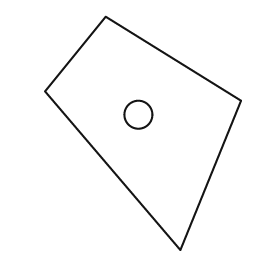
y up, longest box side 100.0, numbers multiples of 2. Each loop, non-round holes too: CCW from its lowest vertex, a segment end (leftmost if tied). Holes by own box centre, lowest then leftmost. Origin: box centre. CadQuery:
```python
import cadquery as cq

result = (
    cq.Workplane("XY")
    .moveTo(16.0, -50.0)
    .lineTo(42.0, 14.0)
    .lineTo(-16.0, 50.0)
    .lineTo(-42.0, 18.0)
    .close()
    .moveTo(-2.0, 8.0)
    .circle(6.0)
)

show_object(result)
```